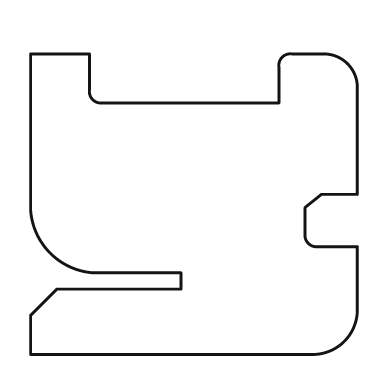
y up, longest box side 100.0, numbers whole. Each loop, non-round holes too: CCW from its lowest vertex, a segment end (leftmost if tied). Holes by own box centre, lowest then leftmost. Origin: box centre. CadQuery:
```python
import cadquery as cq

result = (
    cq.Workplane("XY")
    .moveTo(-50.0, -46.0)
    .lineTo(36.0, -46.0)
    .threePointArc((46.0, -42.0), (50.0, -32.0))
    .lineTo(50.0, -13.0)
    .lineTo(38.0, -13.0)
    .threePointArc((35.0, -12.0), (34.0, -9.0))
    .lineTo(34.0, -1.0)
    .lineTo(39.0, 3.0)
    .lineTo(50.0, 3.0)
    .lineTo(50.0, 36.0)
    .threePointArc((47.0, 43.0), (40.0, 46.0))
    .lineTo(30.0, 46.0)
    .threePointArc((27.0, 45.0), (26.0, 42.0))
    .lineTo(26.0, 31.0)
    .lineTo(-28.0, 31.0)
    .threePointArc((-31.0, 32.0), (-32.0, 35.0))
    .lineTo(-32.0, 46.0)
    .lineTo(-50.0, 46.0)
    .lineTo(-50.0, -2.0)
    .threePointArc((-44.0, -15.0), (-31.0, -21.0))
    .lineTo(-4.0, -21.0)
    .lineTo(-4.0, -26.0)
    .lineTo(-42.0, -26.0)
    .lineTo(-50.0, -34.0)
    .close()
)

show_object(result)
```